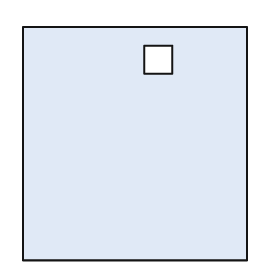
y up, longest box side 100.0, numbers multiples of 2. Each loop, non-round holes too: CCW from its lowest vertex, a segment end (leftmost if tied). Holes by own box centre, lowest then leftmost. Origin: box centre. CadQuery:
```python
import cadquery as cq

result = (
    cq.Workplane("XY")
    .moveTo(-48.0, -50.0)
    .lineTo(48.0, -50.0)
    .lineTo(48.0, 50.0)
    .lineTo(-48.0, 50.0)
    .close()
    .moveTo(4.0, 30.0)
    .lineTo(16.0, 30.0)
    .lineTo(16.0, 42.0)
    .lineTo(4.0, 42.0)
    .close()
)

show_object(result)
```